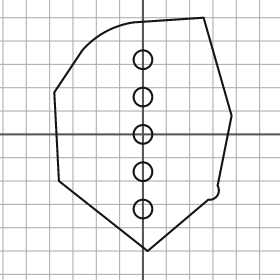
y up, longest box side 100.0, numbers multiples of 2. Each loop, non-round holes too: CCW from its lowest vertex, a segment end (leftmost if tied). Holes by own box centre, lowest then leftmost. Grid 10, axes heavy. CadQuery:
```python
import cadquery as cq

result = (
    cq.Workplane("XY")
    .moveTo(2.0, -50.0)
    .lineTo(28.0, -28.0)
    .threePointArc((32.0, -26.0), (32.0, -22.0))
    .lineTo(38.0, 8.0)
    .lineTo(26.0, 50.0)
    .lineTo(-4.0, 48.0)
    .threePointArc((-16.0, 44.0), (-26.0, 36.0))
    .lineTo(-38.0, 18.0)
    .lineTo(-36.0, -20.0)
    .close()
    .moveTo(0.0, -32.0)
    .circle(4.0)
    .moveTo(0.0, -16.0)
    .circle(4.0)
    .moveTo(0.0, 0.0)
    .circle(4.0)
    .moveTo(0.0, 16.0)
    .circle(4.0)
    .moveTo(0.0, 32.0)
    .circle(4.0)
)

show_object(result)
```